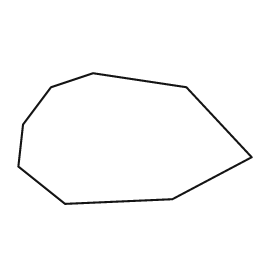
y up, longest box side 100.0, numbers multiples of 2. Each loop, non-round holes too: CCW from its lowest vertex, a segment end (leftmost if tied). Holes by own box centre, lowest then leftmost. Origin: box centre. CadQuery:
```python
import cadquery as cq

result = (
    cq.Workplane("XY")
    .moveTo(-30.0, -28.0)
    .lineTo(16.0, -26.0)
    .lineTo(50.0, -8.0)
    .lineTo(22.0, 22.0)
    .lineTo(-18.0, 28.0)
    .lineTo(-36.0, 22.0)
    .lineTo(-48.0, 6.0)
    .lineTo(-50.0, -12.0)
    .close()
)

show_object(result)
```